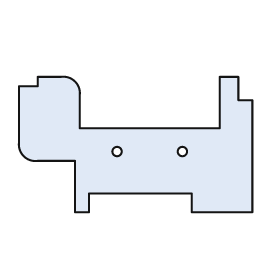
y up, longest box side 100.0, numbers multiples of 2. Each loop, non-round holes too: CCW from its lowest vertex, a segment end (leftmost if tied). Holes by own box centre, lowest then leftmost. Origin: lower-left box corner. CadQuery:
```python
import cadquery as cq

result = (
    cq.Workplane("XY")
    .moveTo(24.0, 0.0)
    .lineTo(30.0, 0.0)
    .lineTo(30.0, 8.0)
    .lineTo(74.0, 8.0)
    .lineTo(74.0, 0.0)
    .lineTo(100.0, 0.0)
    .lineTo(100.0, 48.0)
    .lineTo(94.0, 48.0)
    .lineTo(94.0, 58.0)
    .lineTo(86.0, 58.0)
    .lineTo(86.0, 36.0)
    .lineTo(26.0, 36.0)
    .lineTo(26.0, 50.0)
    .threePointArc((24.0, 56.0), (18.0, 58.0))
    .lineTo(8.0, 58.0)
    .lineTo(8.0, 54.0)
    .lineTo(0.0, 54.0)
    .lineTo(0.0, 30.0)
    .threePointArc((2.0, 24.0), (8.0, 22.0))
    .lineTo(24.0, 22.0)
    .close()
    .moveTo(42.0, 26.0)
    .circle(2.0)
    .moveTo(70.0, 26.0)
    .circle(2.0)
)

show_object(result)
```